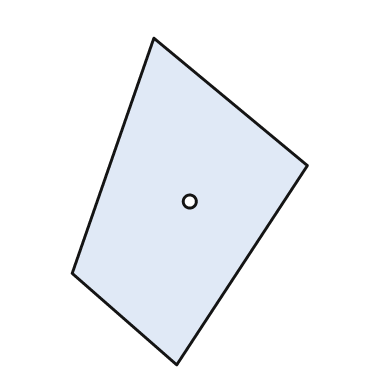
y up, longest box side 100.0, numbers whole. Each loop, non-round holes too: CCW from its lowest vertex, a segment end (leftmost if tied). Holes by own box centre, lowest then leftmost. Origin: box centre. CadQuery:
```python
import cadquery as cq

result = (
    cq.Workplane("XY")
    .moveTo(-4.0, -50.0)
    .lineTo(36.0, 11.0)
    .lineTo(-11.0, 50.0)
    .lineTo(-36.0, -22.0)
    .close()
    .moveTo(0.0, 0.0)
    .circle(2.0)
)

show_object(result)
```